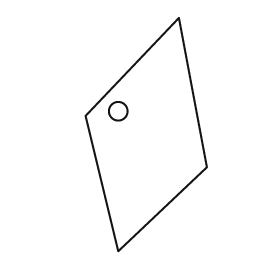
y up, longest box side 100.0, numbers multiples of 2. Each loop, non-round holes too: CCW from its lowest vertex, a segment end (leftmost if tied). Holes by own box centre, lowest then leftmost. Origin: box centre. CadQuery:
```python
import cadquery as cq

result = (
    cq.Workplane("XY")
    .moveTo(-12.0, -50.0)
    .lineTo(26.0, -14.0)
    .lineTo(14.0, 50.0)
    .lineTo(-26.0, 8.0)
    .close()
    .moveTo(-12.0, 10.0)
    .circle(4.0)
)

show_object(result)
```